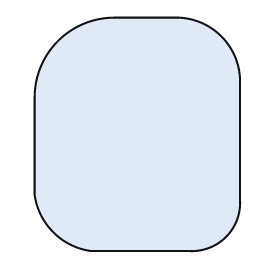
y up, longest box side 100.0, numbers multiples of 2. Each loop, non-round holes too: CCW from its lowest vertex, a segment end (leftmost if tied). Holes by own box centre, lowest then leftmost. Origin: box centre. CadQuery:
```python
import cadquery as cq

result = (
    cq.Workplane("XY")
    .moveTo(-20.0, -50.0)
    .lineTo(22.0, -50.0)
    .threePointArc((38.0, -44.0), (44.0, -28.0))
    .lineTo(44.0, 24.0)
    .threePointArc((36.0, 42.0), (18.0, 50.0))
    .lineTo(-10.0, 50.0)
    .threePointArc((-34.0, 40.0), (-44.0, 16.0))
    .lineTo(-44.0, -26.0)
    .threePointArc((-36.0, -42.0), (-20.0, -50.0))
    .close()
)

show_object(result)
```